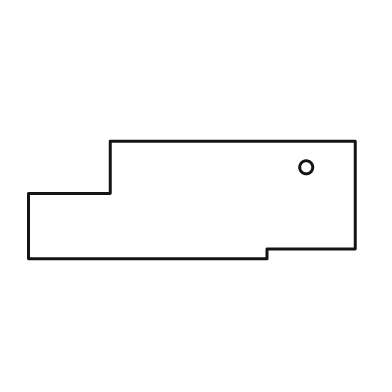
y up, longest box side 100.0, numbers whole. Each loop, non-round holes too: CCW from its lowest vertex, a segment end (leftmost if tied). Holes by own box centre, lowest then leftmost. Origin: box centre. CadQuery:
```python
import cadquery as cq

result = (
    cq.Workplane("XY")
    .moveTo(-50.0, -18.0)
    .lineTo(23.0, -18.0)
    .lineTo(23.0, -15.0)
    .lineTo(50.0, -15.0)
    .lineTo(50.0, 18.0)
    .lineTo(-25.0, 18.0)
    .lineTo(-25.0, 2.0)
    .lineTo(-50.0, 2.0)
    .close()
    .moveTo(35.0, 10.0)
    .circle(2.0)
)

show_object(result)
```